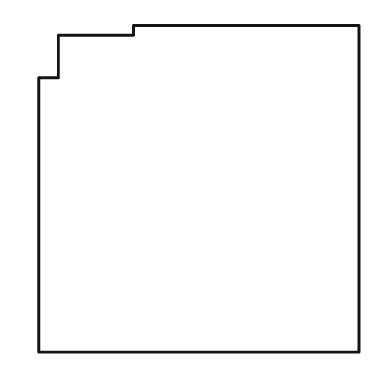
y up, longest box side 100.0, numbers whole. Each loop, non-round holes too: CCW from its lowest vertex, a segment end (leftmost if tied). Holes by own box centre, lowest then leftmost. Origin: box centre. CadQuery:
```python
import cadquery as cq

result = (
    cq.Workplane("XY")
    .moveTo(-49.0, -50.0)
    .lineTo(49.0, -50.0)
    .lineTo(49.0, 50.0)
    .lineTo(-20.0, 50.0)
    .lineTo(-20.0, 47.0)
    .lineTo(-43.0, 47.0)
    .lineTo(-43.0, 34.0)
    .lineTo(-49.0, 34.0)
    .close()
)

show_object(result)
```